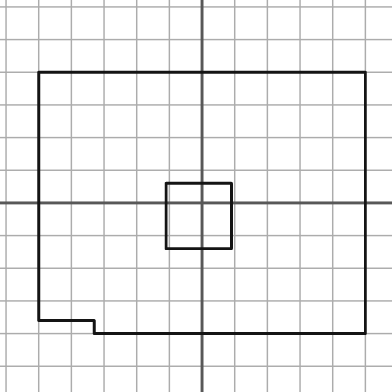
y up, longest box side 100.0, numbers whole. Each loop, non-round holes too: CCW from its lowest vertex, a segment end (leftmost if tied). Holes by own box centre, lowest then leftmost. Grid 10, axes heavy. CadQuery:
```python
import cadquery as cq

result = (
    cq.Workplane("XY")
    .moveTo(-33.0, -40.0)
    .lineTo(50.0, -40.0)
    .lineTo(50.0, 40.0)
    .lineTo(-50.0, 40.0)
    .lineTo(-50.0, -36.0)
    .lineTo(-33.0, -36.0)
    .close()
    .moveTo(-11.0, -14.0)
    .lineTo(9.0, -14.0)
    .lineTo(9.0, 6.0)
    .lineTo(-11.0, 6.0)
    .close()
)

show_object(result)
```